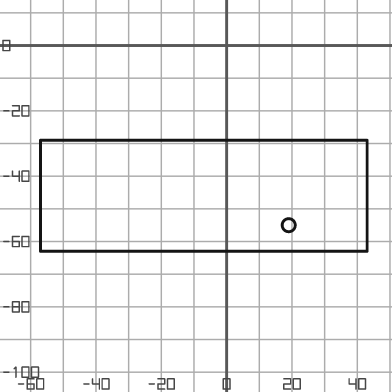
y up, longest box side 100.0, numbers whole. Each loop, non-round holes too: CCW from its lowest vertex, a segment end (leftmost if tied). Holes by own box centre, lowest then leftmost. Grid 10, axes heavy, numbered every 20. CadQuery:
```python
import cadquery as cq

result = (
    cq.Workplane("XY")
    .moveTo(-57.0, -63.0)
    .lineTo(43.0, -63.0)
    .lineTo(43.0, -29.0)
    .lineTo(-57.0, -29.0)
    .close()
    .moveTo(19.0, -55.0)
    .circle(2.0)
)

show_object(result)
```